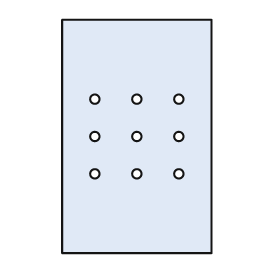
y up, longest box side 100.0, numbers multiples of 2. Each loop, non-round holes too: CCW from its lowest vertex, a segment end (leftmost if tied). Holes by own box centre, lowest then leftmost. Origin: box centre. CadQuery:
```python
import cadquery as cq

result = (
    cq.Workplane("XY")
    .moveTo(-32.0, -50.0)
    .lineTo(32.0, -50.0)
    .lineTo(32.0, 50.0)
    .lineTo(-32.0, 50.0)
    .close()
    .moveTo(-18.0, -16.0)
    .circle(2.0)
    .moveTo(0.0, -16.0)
    .circle(2.0)
    .moveTo(18.0, -16.0)
    .circle(2.0)
    .moveTo(-18.0, 0.0)
    .circle(2.0)
    .moveTo(0.0, 0.0)
    .circle(2.0)
    .moveTo(18.0, 0.0)
    .circle(2.0)
    .moveTo(-18.0, 16.0)
    .circle(2.0)
    .moveTo(0.0, 16.0)
    .circle(2.0)
    .moveTo(18.0, 16.0)
    .circle(2.0)
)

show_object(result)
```